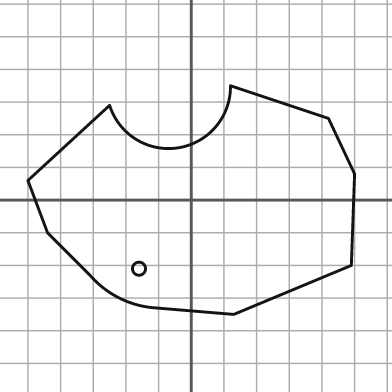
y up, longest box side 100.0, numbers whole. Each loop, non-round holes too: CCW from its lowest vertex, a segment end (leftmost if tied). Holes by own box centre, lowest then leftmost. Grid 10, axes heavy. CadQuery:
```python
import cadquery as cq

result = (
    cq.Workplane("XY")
    .moveTo(13.0, -35.0)
    .lineTo(49.0, -20.0)
    .lineTo(50.0, 8.0)
    .lineTo(42.0, 25.0)
    .lineTo(12.0, 35.0)
    .threePointArc((-4.0, 16.0), (-25.0, 29.0))
    .lineTo(-50.0, 6.0)
    .lineTo(-44.0, -10.0)
    .lineTo(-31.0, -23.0)
    .threePointArc((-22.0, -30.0), (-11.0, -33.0))
    .close()
    .moveTo(-16.0, -21.0)
    .circle(2.0)
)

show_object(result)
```